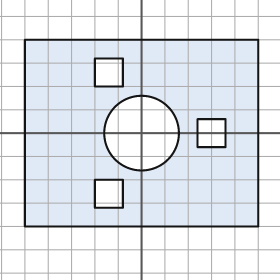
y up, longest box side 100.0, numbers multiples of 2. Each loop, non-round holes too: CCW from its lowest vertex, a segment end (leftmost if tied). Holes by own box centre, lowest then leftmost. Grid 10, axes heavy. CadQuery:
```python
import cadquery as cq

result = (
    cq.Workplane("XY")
    .moveTo(-50.0, -40.0)
    .lineTo(50.0, -40.0)
    .lineTo(50.0, 40.0)
    .lineTo(-50.0, 40.0)
    .close()
    .moveTo(-20.0, -32.0)
    .lineTo(-8.0, -32.0)
    .lineTo(-8.0, -20.0)
    .lineTo(-20.0, -20.0)
    .close()
    .moveTo(0.0, 0.0)
    .circle(16.0)
    .moveTo(24.0, -6.0)
    .lineTo(36.0, -6.0)
    .lineTo(36.0, 6.0)
    .lineTo(24.0, 6.0)
    .close()
    .moveTo(-20.0, 20.0)
    .lineTo(-8.0, 20.0)
    .lineTo(-8.0, 32.0)
    .lineTo(-20.0, 32.0)
    .close()
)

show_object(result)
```